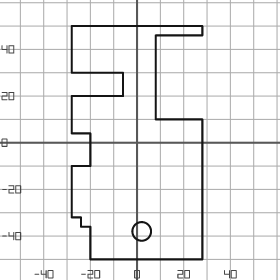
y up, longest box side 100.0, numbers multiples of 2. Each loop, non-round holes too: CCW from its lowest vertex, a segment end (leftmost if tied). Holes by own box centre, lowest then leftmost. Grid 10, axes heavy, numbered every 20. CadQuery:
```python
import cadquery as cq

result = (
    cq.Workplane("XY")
    .moveTo(-20.0, -50.0)
    .lineTo(28.0, -50.0)
    .lineTo(28.0, 10.0)
    .lineTo(8.0, 10.0)
    .lineTo(8.0, 46.0)
    .lineTo(28.0, 46.0)
    .lineTo(28.0, 50.0)
    .lineTo(-28.0, 50.0)
    .lineTo(-28.0, 30.0)
    .lineTo(-6.0, 30.0)
    .lineTo(-6.0, 20.0)
    .lineTo(-28.0, 20.0)
    .lineTo(-28.0, 4.0)
    .lineTo(-20.0, 4.0)
    .lineTo(-20.0, -10.0)
    .lineTo(-28.0, -10.0)
    .lineTo(-28.0, -32.0)
    .lineTo(-24.0, -32.0)
    .lineTo(-24.0, -36.0)
    .lineTo(-20.0, -36.0)
    .close()
    .moveTo(2.0, -38.0)
    .circle(4.0)
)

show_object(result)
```